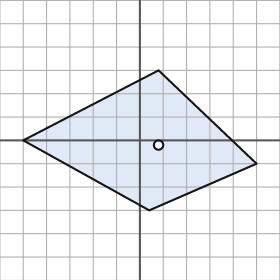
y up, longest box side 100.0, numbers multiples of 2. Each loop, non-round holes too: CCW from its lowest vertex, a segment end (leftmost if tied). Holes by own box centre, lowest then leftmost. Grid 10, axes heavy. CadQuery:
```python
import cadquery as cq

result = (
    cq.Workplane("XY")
    .moveTo(4.0, -30.0)
    .lineTo(50.0, -10.0)
    .lineTo(8.0, 30.0)
    .lineTo(-50.0, 0.0)
    .close()
    .moveTo(8.0, -2.0)
    .circle(2.0)
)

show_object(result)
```